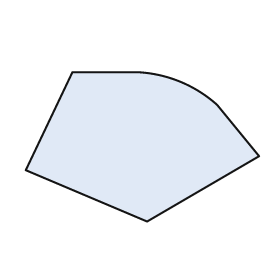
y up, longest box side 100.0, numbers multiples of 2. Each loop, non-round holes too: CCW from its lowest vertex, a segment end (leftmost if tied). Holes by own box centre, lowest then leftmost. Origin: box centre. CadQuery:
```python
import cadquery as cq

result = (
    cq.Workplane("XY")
    .moveTo(2.0, -32.0)
    .lineTo(50.0, -4.0)
    .lineTo(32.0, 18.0)
    .threePointArc((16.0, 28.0), (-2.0, 32.0))
    .lineTo(-30.0, 32.0)
    .lineTo(-50.0, -10.0)
    .close()
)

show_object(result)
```